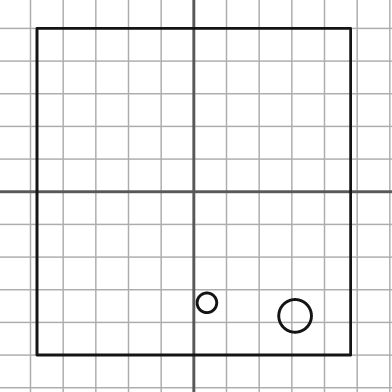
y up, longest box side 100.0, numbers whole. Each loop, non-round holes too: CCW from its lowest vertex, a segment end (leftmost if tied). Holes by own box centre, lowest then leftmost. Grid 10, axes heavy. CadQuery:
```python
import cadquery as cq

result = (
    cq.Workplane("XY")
    .moveTo(-48.0, -50.0)
    .lineTo(48.0, -50.0)
    .lineTo(48.0, 50.0)
    .lineTo(-48.0, 50.0)
    .close()
    .moveTo(31.0, -38.0)
    .circle(5.0)
    .moveTo(4.0, -34.0)
    .circle(3.0)
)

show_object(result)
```